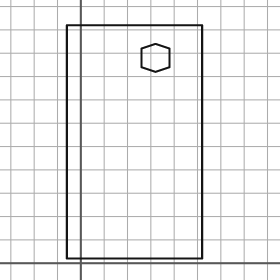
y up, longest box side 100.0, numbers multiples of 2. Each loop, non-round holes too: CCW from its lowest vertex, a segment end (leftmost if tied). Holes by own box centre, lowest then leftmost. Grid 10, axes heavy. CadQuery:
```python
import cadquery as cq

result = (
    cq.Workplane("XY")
    .moveTo(-6.0, 2.0)
    .lineTo(52.0, 2.0)
    .lineTo(52.0, 102.0)
    .lineTo(-6.0, 102.0)
    .close()
    .moveTo(32.0, 82.0)
    .lineTo(38.0, 84.0)
    .lineTo(38.0, 92.0)
    .lineTo(32.0, 94.0)
    .lineTo(26.0, 92.0)
    .lineTo(26.0, 84.0)
    .close()
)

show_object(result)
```